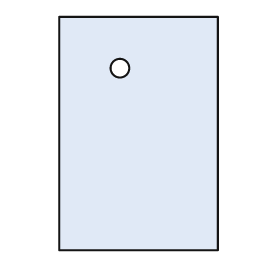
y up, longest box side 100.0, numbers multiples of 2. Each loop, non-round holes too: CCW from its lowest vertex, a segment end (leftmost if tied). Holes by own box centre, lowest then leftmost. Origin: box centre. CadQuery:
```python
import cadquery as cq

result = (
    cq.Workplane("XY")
    .moveTo(-34.0, -50.0)
    .lineTo(34.0, -50.0)
    .lineTo(34.0, 50.0)
    .lineTo(-34.0, 50.0)
    .close()
    .moveTo(-8.0, 28.0)
    .circle(4.0)
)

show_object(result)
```